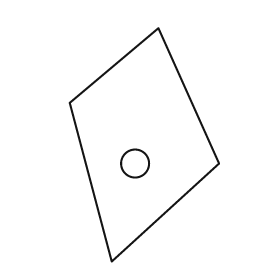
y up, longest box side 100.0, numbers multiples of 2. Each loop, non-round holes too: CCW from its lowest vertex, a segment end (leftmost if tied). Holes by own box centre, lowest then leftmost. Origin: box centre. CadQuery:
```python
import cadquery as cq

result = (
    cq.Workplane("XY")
    .moveTo(-14.0, -50.0)
    .lineTo(32.0, -8.0)
    .lineTo(6.0, 50.0)
    .lineTo(-32.0, 18.0)
    .close()
    .moveTo(-4.0, -8.0)
    .circle(6.0)
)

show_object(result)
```